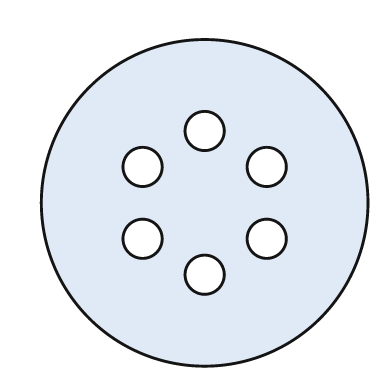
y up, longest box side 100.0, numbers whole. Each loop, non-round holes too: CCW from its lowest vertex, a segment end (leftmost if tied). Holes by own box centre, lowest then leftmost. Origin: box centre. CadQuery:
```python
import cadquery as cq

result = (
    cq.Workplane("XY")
    .moveTo(0.0, 0.0)
    .circle(50.0)
    .moveTo(0.0, -22.0)
    .circle(6.0)
    .moveTo(-19.0, -11.0)
    .circle(6.0)
    .moveTo(19.0, -11.0)
    .circle(6.0)
    .moveTo(-19.0, 11.0)
    .circle(6.0)
    .moveTo(19.0, 11.0)
    .circle(6.0)
    .moveTo(0.0, 22.0)
    .circle(6.0)
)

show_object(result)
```